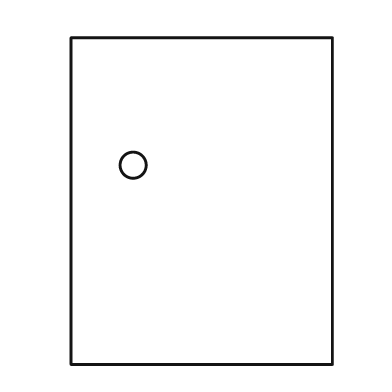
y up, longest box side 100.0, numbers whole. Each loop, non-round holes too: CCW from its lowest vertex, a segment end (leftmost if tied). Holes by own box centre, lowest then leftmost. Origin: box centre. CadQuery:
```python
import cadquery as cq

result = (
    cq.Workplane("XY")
    .moveTo(-40.0, -50.0)
    .lineTo(40.0, -50.0)
    .lineTo(40.0, 50.0)
    .lineTo(-40.0, 50.0)
    .close()
    .moveTo(-21.0, 11.0)
    .circle(4.0)
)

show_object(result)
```